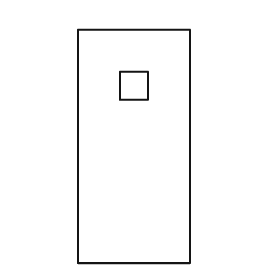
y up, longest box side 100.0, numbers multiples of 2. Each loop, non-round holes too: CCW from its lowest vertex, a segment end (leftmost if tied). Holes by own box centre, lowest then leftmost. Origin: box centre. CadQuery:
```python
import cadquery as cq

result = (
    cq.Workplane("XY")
    .moveTo(-24.0, -50.0)
    .lineTo(24.0, -50.0)
    .lineTo(24.0, 50.0)
    .lineTo(-24.0, 50.0)
    .close()
    .moveTo(-6.0, 20.0)
    .lineTo(6.0, 20.0)
    .lineTo(6.0, 32.0)
    .lineTo(-6.0, 32.0)
    .close()
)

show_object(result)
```